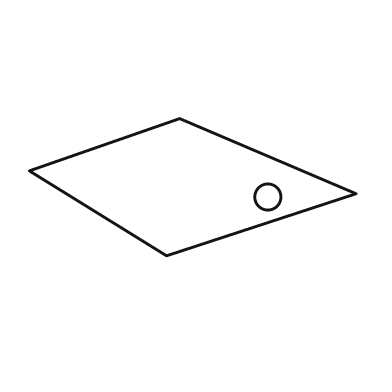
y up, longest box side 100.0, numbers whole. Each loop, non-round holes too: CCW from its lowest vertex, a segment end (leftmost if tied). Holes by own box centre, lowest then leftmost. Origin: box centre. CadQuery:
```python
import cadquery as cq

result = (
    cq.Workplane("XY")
    .moveTo(-8.0, -21.0)
    .lineTo(50.0, -2.0)
    .lineTo(-4.0, 21.0)
    .lineTo(-50.0, 5.0)
    .close()
    .moveTo(23.0, -3.0)
    .circle(4.0)
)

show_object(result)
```